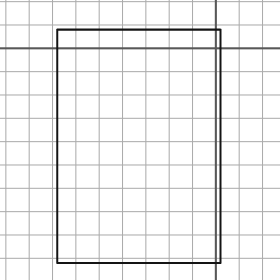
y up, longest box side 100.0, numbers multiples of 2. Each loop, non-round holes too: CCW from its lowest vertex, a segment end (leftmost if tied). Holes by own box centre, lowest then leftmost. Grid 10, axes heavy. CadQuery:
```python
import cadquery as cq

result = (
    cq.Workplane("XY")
    .moveTo(-68.0, -92.0)
    .lineTo(2.0, -92.0)
    .lineTo(2.0, 8.0)
    .lineTo(-68.0, 8.0)
    .close()
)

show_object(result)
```